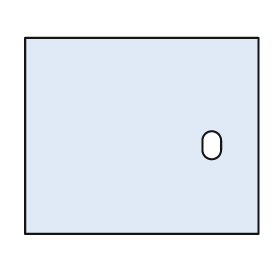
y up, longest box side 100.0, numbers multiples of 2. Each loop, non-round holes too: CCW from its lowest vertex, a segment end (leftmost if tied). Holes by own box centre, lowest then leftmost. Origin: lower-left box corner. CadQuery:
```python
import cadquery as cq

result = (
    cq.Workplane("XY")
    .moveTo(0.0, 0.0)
    .lineTo(100.0, 0.0)
    .lineTo(100.0, 84.0)
    .lineTo(0.0, 84.0)
    .close()
    .moveTo(76.0, 36.0)
    .threePointArc((80.0, 32.0), (84.0, 36.0))
    .lineTo(84.0, 40.0)
    .threePointArc((80.0, 44.0), (76.0, 40.0))
    .close()
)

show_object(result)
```